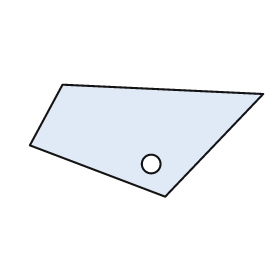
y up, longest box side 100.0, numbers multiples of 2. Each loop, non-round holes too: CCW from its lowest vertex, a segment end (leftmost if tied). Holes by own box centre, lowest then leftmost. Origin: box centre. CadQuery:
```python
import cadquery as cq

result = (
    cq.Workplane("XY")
    .moveTo(8.0, -24.0)
    .lineTo(50.0, 20.0)
    .lineTo(-36.0, 24.0)
    .lineTo(-50.0, -2.0)
    .close()
    .moveTo(2.0, -10.0)
    .circle(4.0)
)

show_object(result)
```